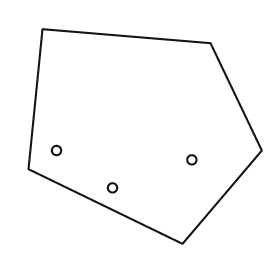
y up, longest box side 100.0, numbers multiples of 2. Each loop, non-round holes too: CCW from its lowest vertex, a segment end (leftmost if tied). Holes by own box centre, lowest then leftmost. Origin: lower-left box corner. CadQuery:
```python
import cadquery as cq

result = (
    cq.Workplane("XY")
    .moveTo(66.0, 0.0)
    .lineTo(100.0, 40.0)
    .lineTo(78.0, 86.0)
    .lineTo(6.0, 92.0)
    .lineTo(0.0, 32.0)
    .close()
    .moveTo(36.0, 24.0)
    .circle(2.0)
    .moveTo(70.0, 36.0)
    .circle(2.0)
    .moveTo(12.0, 40.0)
    .circle(2.0)
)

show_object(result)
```